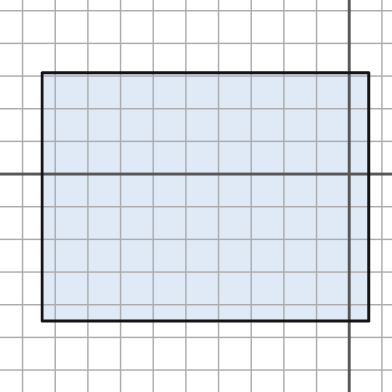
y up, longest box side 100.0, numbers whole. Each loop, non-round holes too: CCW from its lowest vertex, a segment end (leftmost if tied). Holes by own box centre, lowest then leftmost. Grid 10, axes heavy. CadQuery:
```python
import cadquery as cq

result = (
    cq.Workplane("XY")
    .moveTo(-94.0, -45.0)
    .lineTo(6.0, -45.0)
    .lineTo(6.0, 31.0)
    .lineTo(-94.0, 31.0)
    .close()
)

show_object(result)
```